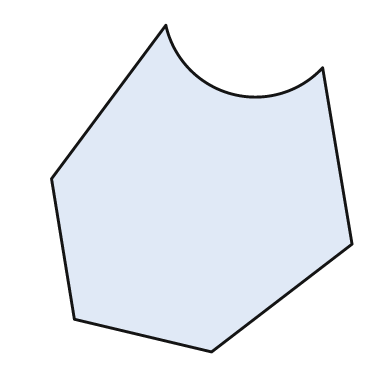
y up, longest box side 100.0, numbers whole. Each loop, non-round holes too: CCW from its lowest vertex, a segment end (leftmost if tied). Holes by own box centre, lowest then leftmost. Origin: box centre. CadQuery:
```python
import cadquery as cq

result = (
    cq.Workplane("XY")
    .moveTo(3.0, -50.0)
    .lineTo(46.0, -17.0)
    .lineTo(37.0, 37.0)
    .threePointArc((9.0, 29.0), (-11.0, 50.0))
    .lineTo(-46.0, 3.0)
    .lineTo(-39.0, -40.0)
    .close()
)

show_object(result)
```